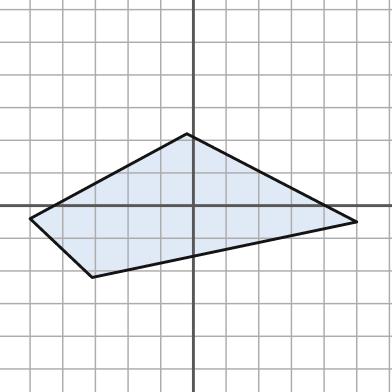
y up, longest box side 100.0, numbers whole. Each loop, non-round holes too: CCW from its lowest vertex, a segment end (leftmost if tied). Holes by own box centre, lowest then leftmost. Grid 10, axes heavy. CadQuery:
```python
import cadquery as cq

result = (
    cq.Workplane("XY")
    .moveTo(-31.0, -22.0)
    .lineTo(50.0, -5.0)
    .lineTo(-2.0, 22.0)
    .lineTo(-50.0, -4.0)
    .close()
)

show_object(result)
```